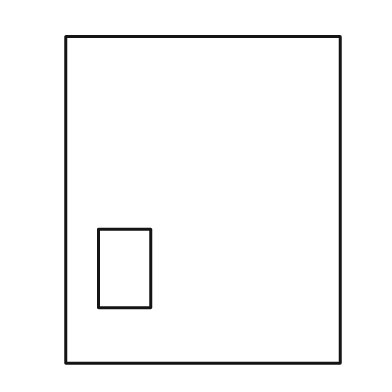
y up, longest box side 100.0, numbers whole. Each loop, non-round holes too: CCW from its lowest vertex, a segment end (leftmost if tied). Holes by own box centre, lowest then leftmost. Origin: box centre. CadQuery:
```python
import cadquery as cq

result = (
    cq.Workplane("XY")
    .moveTo(-42.0, -50.0)
    .lineTo(42.0, -50.0)
    .lineTo(42.0, 50.0)
    .lineTo(-42.0, 50.0)
    .close()
    .moveTo(-32.0, -33.0)
    .lineTo(-16.0, -33.0)
    .lineTo(-16.0, -9.0)
    .lineTo(-32.0, -9.0)
    .close()
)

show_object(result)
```